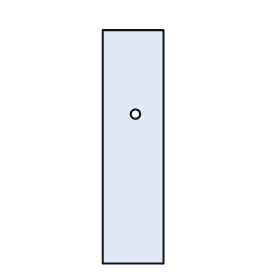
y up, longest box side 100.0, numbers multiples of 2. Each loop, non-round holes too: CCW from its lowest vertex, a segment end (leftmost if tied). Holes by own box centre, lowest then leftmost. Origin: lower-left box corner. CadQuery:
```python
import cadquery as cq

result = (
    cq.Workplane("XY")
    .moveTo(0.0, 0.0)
    .lineTo(26.0, 0.0)
    .lineTo(26.0, 100.0)
    .lineTo(0.0, 100.0)
    .close()
    .moveTo(14.0, 64.0)
    .circle(2.0)
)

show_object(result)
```